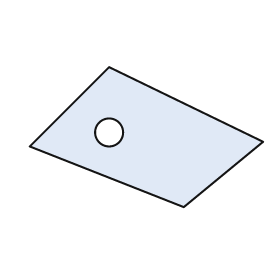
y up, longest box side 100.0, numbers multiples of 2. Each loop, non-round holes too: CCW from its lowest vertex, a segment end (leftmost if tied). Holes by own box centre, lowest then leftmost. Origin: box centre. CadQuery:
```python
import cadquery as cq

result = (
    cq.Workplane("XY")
    .moveTo(16.0, -30.0)
    .lineTo(50.0, -2.0)
    .lineTo(-16.0, 30.0)
    .lineTo(-50.0, -4.0)
    .close()
    .moveTo(-16.0, 2.0)
    .circle(6.0)
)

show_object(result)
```